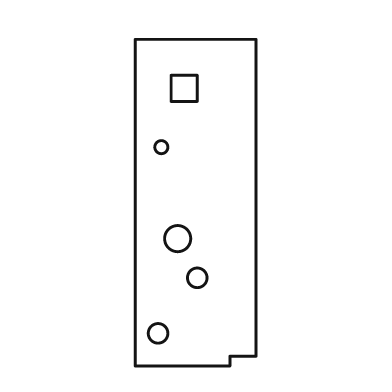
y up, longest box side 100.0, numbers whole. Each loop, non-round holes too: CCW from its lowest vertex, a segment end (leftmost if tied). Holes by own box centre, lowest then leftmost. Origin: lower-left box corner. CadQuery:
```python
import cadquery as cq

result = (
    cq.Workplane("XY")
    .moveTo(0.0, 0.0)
    .lineTo(29.0, 0.0)
    .lineTo(29.0, 3.0)
    .lineTo(37.0, 3.0)
    .lineTo(37.0, 100.0)
    .lineTo(0.0, 100.0)
    .close()
    .moveTo(7.0, 10.0)
    .circle(3.0)
    .moveTo(19.0, 27.0)
    .circle(3.0)
    .moveTo(13.0, 39.0)
    .circle(4.0)
    .moveTo(8.0, 67.0)
    .circle(2.0)
    .moveTo(11.0, 81.0)
    .lineTo(19.0, 81.0)
    .lineTo(19.0, 89.0)
    .lineTo(11.0, 89.0)
    .close()
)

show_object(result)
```